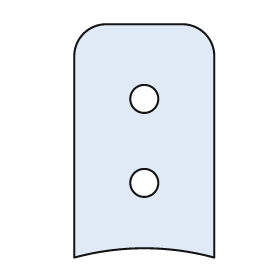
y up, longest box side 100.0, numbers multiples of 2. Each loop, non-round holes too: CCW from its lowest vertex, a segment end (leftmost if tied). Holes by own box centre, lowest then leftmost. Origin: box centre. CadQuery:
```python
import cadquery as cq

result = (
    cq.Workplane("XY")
    .moveTo(-30.0, -50.0)
    .threePointArc((0.0, -46.0), (30.0, -50.0))
    .lineTo(30.0, 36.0)
    .threePointArc((26.0, 46.0), (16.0, 50.0))
    .lineTo(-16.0, 50.0)
    .threePointArc((-26.0, 46.0), (-30.0, 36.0))
    .close()
    .moveTo(0.0, -18.0)
    .circle(6.0)
    .moveTo(0.0, 18.0)
    .circle(6.0)
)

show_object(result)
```